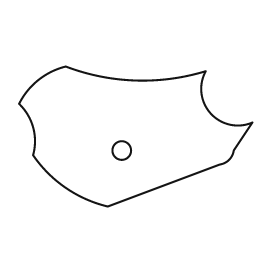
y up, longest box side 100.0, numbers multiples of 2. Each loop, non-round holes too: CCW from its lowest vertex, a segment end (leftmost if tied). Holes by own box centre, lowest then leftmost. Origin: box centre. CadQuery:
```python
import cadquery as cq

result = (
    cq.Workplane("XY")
    .moveTo(-12.0, -30.0)
    .lineTo(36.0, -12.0)
    .threePointArc((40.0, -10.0), (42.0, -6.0))
    .lineTo(50.0, 6.0)
    .threePointArc((32.0, 10.0), (30.0, 28.0))
    .threePointArc((0.0, 24.0), (-30.0, 30.0))
    .threePointArc((-42.0, 24.0), (-50.0, 14.0))
    .threePointArc((-44.0, 4.0), (-44.0, -8.0))
    .threePointArc((-30.0, -22.0), (-12.0, -30.0))
    .close()
    .moveTo(-6.0, -6.0)
    .circle(4.0)
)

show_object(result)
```